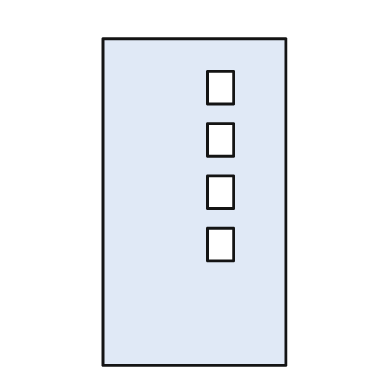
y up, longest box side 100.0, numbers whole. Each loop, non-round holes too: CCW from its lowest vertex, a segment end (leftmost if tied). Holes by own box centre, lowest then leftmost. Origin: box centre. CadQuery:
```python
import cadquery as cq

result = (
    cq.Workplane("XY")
    .moveTo(-28.0, -50.0)
    .lineTo(28.0, -50.0)
    .lineTo(28.0, 50.0)
    .lineTo(-28.0, 50.0)
    .close()
    .moveTo(4.0, -18.0)
    .lineTo(12.0, -18.0)
    .lineTo(12.0, -8.0)
    .lineTo(4.0, -8.0)
    .close()
    .moveTo(4.0, -2.0)
    .lineTo(12.0, -2.0)
    .lineTo(12.0, 8.0)
    .lineTo(4.0, 8.0)
    .close()
    .moveTo(4.0, 14.0)
    .lineTo(12.0, 14.0)
    .lineTo(12.0, 24.0)
    .lineTo(4.0, 24.0)
    .close()
    .moveTo(4.0, 30.0)
    .lineTo(12.0, 30.0)
    .lineTo(12.0, 40.0)
    .lineTo(4.0, 40.0)
    .close()
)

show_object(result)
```